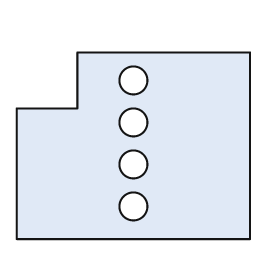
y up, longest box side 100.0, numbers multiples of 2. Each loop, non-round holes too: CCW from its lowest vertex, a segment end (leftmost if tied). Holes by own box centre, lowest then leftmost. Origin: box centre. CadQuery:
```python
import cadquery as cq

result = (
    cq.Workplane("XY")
    .moveTo(-50.0, -40.0)
    .lineTo(50.0, -40.0)
    .lineTo(50.0, 40.0)
    .lineTo(-24.0, 40.0)
    .lineTo(-24.0, 16.0)
    .lineTo(-50.0, 16.0)
    .close()
    .moveTo(0.0, -26.0)
    .circle(6.0)
    .moveTo(0.0, -8.0)
    .circle(6.0)
    .moveTo(0.0, 10.0)
    .circle(6.0)
    .moveTo(0.0, 28.0)
    .circle(6.0)
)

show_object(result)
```